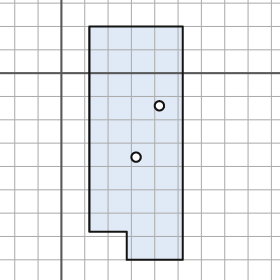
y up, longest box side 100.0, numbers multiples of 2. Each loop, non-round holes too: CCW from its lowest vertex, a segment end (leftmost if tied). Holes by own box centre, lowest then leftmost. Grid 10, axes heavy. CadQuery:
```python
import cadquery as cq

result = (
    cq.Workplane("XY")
    .moveTo(28.0, -80.0)
    .lineTo(52.0, -80.0)
    .lineTo(52.0, 20.0)
    .lineTo(12.0, 20.0)
    .lineTo(12.0, -68.0)
    .lineTo(28.0, -68.0)
    .close()
    .moveTo(32.0, -36.0)
    .circle(2.0)
    .moveTo(42.0, -14.0)
    .circle(2.0)
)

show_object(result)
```